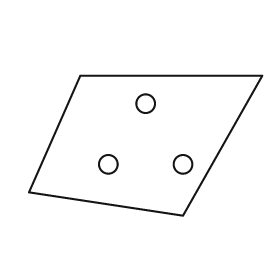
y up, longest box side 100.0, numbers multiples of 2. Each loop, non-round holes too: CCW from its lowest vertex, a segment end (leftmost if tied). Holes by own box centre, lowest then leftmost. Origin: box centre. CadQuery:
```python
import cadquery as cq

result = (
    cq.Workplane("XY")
    .moveTo(16.0, -30.0)
    .lineTo(50.0, 30.0)
    .lineTo(-28.0, 30.0)
    .lineTo(-50.0, -20.0)
    .close()
    .moveTo(-16.0, -8.0)
    .circle(4.0)
    .moveTo(16.0, -8.0)
    .circle(4.0)
    .moveTo(0.0, 18.0)
    .circle(4.0)
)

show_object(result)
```